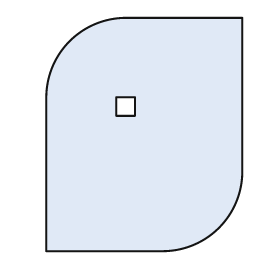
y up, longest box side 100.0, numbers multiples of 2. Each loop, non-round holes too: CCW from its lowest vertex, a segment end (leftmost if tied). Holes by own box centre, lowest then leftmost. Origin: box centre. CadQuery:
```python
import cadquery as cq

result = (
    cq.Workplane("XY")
    .moveTo(-42.0, -50.0)
    .lineTo(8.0, -50.0)
    .threePointArc((32.0, -40.0), (42.0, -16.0))
    .lineTo(42.0, 50.0)
    .lineTo(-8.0, 50.0)
    .threePointArc((-32.0, 40.0), (-42.0, 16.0))
    .close()
    .moveTo(-12.0, 8.0)
    .lineTo(-4.0, 8.0)
    .lineTo(-4.0, 16.0)
    .lineTo(-12.0, 16.0)
    .close()
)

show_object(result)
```